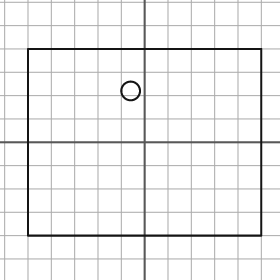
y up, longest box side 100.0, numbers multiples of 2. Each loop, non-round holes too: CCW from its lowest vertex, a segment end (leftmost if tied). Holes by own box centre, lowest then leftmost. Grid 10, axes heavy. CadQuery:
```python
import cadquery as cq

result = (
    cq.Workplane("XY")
    .moveTo(-50.0, -40.0)
    .lineTo(50.0, -40.0)
    .lineTo(50.0, 40.0)
    .lineTo(-50.0, 40.0)
    .close()
    .moveTo(-6.0, 22.0)
    .circle(4.0)
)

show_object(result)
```